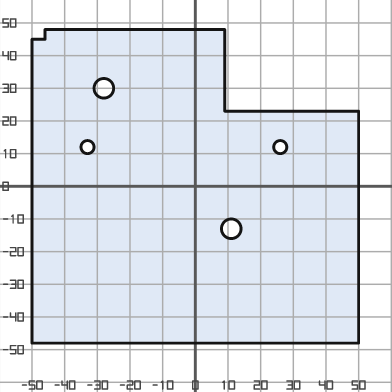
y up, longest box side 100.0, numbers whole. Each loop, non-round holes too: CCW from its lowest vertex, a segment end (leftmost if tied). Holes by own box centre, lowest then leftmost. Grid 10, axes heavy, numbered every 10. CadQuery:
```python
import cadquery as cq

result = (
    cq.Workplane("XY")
    .moveTo(-50.0, -48.0)
    .lineTo(50.0, -48.0)
    .lineTo(50.0, 23.0)
    .lineTo(9.0, 23.0)
    .lineTo(9.0, 48.0)
    .lineTo(-46.0, 48.0)
    .lineTo(-46.0, 45.0)
    .lineTo(-50.0, 45.0)
    .close()
    .moveTo(11.0, -13.0)
    .circle(3.0)
    .moveTo(-33.0, 12.0)
    .circle(2.0)
    .moveTo(26.0, 12.0)
    .circle(2.0)
    .moveTo(-28.0, 30.0)
    .circle(3.0)
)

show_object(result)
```